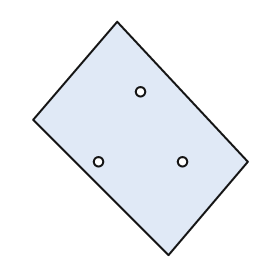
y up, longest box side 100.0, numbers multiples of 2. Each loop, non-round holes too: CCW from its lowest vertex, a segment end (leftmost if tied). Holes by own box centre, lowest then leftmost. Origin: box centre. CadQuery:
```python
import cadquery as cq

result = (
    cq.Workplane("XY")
    .moveTo(12.0, -50.0)
    .lineTo(46.0, -10.0)
    .lineTo(-10.0, 50.0)
    .lineTo(-46.0, 8.0)
    .close()
    .moveTo(-18.0, -10.0)
    .circle(2.0)
    .moveTo(18.0, -10.0)
    .circle(2.0)
    .moveTo(0.0, 20.0)
    .circle(2.0)
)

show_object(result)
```